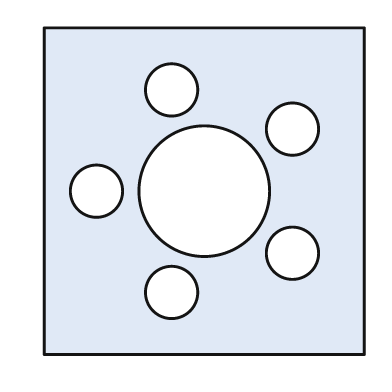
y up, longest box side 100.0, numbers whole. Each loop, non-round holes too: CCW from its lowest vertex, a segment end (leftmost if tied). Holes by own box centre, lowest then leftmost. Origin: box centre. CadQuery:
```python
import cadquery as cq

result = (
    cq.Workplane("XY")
    .moveTo(-49.0, -50.0)
    .lineTo(49.0, -50.0)
    .lineTo(49.0, 50.0)
    .lineTo(-49.0, 50.0)
    .close()
    .moveTo(-10.0, -31.0)
    .circle(8.0)
    .moveTo(27.0, -19.0)
    .circle(8.0)
    .moveTo(-33.0, 0.0)
    .circle(8.0)
    .moveTo(0.0, 0.0)
    .circle(20.0)
    .moveTo(27.0, 19.0)
    .circle(8.0)
    .moveTo(-10.0, 31.0)
    .circle(8.0)
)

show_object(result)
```